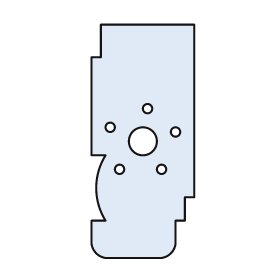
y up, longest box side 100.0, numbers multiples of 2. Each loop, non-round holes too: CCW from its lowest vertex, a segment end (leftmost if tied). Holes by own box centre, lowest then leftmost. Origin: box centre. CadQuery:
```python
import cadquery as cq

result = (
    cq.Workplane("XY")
    .moveTo(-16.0, -50.0)
    .lineTo(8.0, -50.0)
    .threePointArc((12.0, -48.0), (14.0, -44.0))
    .lineTo(14.0, -34.0)
    .lineTo(18.0, -34.0)
    .lineTo(18.0, -24.0)
    .lineTo(22.0, -24.0)
    .lineTo(22.0, 50.0)
    .lineTo(-18.0, 50.0)
    .lineTo(-18.0, 36.0)
    .lineTo(-22.0, 36.0)
    .lineTo(-22.0, -6.0)
    .lineTo(-16.0, -6.0)
    .threePointArc((-20.0, -20.0), (-16.0, -34.0))
    .lineTo(-22.0, -34.0)
    .lineTo(-22.0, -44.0)
    .threePointArc((-20.0, -48.0), (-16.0, -50.0))
    .close()
    .moveTo(-10.0, -12.0)
    .circle(2.0)
    .moveTo(8.0, -12.0)
    .circle(2.0)
    .moveTo(0.0, 0.0)
    .circle(6.0)
    .moveTo(14.0, 4.0)
    .circle(2.0)
    .moveTo(-14.0, 6.0)
    .circle(2.0)
    .moveTo(2.0, 14.0)
    .circle(2.0)
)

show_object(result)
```